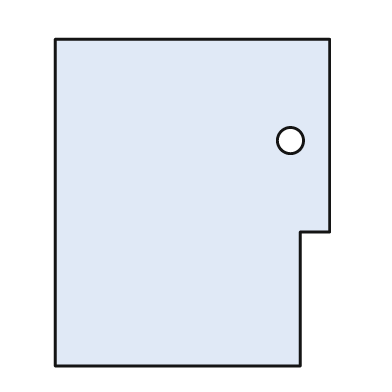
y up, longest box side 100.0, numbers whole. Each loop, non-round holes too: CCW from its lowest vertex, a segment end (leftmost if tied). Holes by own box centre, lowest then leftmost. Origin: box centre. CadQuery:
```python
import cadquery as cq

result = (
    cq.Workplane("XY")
    .moveTo(-42.0, -50.0)
    .lineTo(33.0, -50.0)
    .lineTo(33.0, -9.0)
    .lineTo(42.0, -9.0)
    .lineTo(42.0, 50.0)
    .lineTo(-42.0, 50.0)
    .close()
    .moveTo(30.0, 19.0)
    .circle(4.0)
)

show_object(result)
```